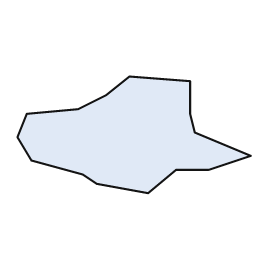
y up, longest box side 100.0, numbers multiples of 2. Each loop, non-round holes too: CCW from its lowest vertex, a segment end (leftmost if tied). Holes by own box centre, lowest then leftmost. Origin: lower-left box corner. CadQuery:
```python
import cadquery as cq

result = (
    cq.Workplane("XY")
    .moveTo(56.0, 0.0)
    .lineTo(68.0, 10.0)
    .lineTo(82.0, 10.0)
    .lineTo(100.0, 16.0)
    .lineTo(76.0, 26.0)
    .lineTo(74.0, 34.0)
    .lineTo(74.0, 48.0)
    .lineTo(48.0, 50.0)
    .lineTo(38.0, 42.0)
    .lineTo(26.0, 36.0)
    .lineTo(4.0, 34.0)
    .lineTo(0.0, 24.0)
    .lineTo(6.0, 14.0)
    .lineTo(28.0, 8.0)
    .lineTo(34.0, 4.0)
    .close()
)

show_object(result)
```